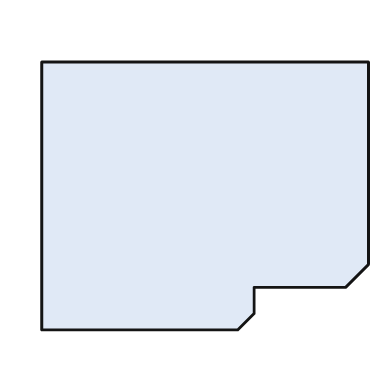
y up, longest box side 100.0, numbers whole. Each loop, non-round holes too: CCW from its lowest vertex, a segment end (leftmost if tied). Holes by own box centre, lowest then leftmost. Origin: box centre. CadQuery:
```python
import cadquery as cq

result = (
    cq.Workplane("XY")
    .moveTo(-50.0, -41.0)
    .lineTo(10.0, -41.0)
    .lineTo(15.0, -36.0)
    .lineTo(15.0, -28.0)
    .lineTo(43.0, -28.0)
    .lineTo(50.0, -21.0)
    .lineTo(50.0, 41.0)
    .lineTo(-50.0, 41.0)
    .close()
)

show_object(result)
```